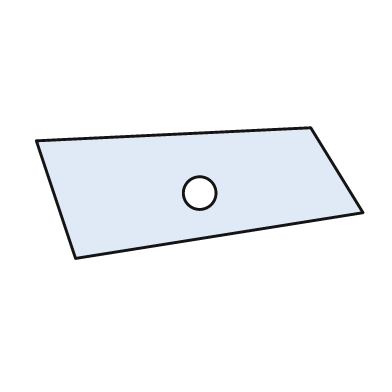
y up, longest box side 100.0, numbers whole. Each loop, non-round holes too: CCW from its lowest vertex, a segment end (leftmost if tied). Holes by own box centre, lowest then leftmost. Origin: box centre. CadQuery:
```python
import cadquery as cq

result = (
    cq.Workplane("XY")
    .moveTo(-38.0, -20.0)
    .lineTo(50.0, -6.0)
    .lineTo(34.0, 20.0)
    .lineTo(-50.0, 16.0)
    .close()
    .moveTo(0.0, 0.0)
    .circle(5.0)
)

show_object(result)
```